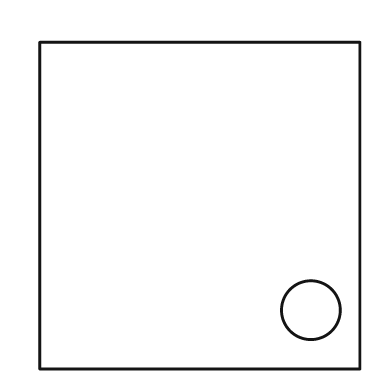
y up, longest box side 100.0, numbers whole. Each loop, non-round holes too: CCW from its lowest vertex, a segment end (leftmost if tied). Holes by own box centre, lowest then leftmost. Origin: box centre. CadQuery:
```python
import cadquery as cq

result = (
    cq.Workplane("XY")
    .moveTo(-49.0, -50.0)
    .lineTo(49.0, -50.0)
    .lineTo(49.0, 50.0)
    .lineTo(-49.0, 50.0)
    .close()
    .moveTo(34.0, -32.0)
    .circle(9.0)
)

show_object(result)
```